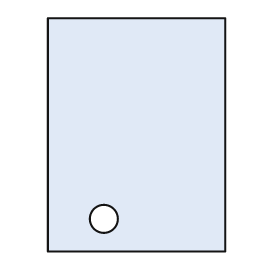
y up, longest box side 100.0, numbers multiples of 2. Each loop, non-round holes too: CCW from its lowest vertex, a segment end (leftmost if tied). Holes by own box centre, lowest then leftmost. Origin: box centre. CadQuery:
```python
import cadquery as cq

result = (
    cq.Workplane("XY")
    .moveTo(-38.0, -50.0)
    .lineTo(38.0, -50.0)
    .lineTo(38.0, 50.0)
    .lineTo(-38.0, 50.0)
    .close()
    .moveTo(-14.0, -36.0)
    .circle(6.0)
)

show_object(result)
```